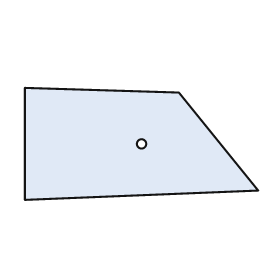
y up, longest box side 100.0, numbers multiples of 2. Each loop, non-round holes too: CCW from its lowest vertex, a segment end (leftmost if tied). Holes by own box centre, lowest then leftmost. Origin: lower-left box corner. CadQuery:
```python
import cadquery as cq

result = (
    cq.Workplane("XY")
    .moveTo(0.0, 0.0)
    .lineTo(100.0, 4.0)
    .lineTo(66.0, 46.0)
    .lineTo(0.0, 48.0)
    .close()
    .moveTo(50.0, 24.0)
    .circle(2.0)
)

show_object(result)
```